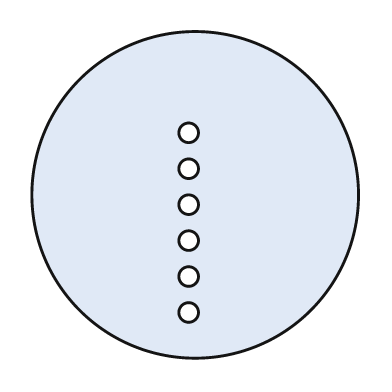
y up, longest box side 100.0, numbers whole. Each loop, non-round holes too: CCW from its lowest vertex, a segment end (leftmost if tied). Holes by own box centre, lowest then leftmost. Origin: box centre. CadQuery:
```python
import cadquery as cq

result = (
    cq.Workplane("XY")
    .moveTo(0.0, 0.0)
    .circle(50.0)
    .moveTo(-2.0, -36.0)
    .circle(3.0)
    .moveTo(-2.0, -25.0)
    .circle(3.0)
    .moveTo(-2.0, -14.0)
    .circle(3.0)
    .moveTo(-2.0, -3.0)
    .circle(3.0)
    .moveTo(-2.0, 8.0)
    .circle(3.0)
    .moveTo(-2.0, 19.0)
    .circle(3.0)
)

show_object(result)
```